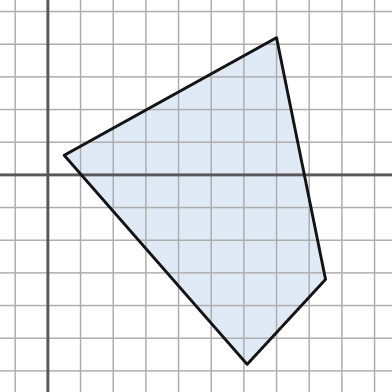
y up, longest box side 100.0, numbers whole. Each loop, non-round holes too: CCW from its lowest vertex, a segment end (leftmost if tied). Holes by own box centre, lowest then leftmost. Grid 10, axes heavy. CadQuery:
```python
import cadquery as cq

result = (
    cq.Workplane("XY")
    .moveTo(61.0, -58.0)
    .lineTo(85.0, -32.0)
    .lineTo(70.0, 42.0)
    .lineTo(5.0, 6.0)
    .close()
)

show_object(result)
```